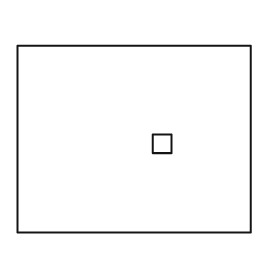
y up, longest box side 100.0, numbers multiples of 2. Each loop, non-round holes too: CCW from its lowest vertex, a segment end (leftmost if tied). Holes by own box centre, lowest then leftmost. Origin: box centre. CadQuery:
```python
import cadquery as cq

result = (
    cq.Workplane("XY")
    .moveTo(-50.0, -40.0)
    .lineTo(50.0, -40.0)
    .lineTo(50.0, 40.0)
    .lineTo(-50.0, 40.0)
    .close()
    .moveTo(8.0, -6.0)
    .lineTo(16.0, -6.0)
    .lineTo(16.0, 2.0)
    .lineTo(8.0, 2.0)
    .close()
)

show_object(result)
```